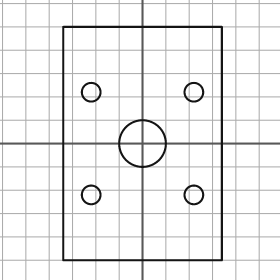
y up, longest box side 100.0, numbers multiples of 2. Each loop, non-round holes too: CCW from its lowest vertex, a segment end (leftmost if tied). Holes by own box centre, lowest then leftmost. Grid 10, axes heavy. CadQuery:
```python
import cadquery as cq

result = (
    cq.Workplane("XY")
    .moveTo(-34.0, -50.0)
    .lineTo(34.0, -50.0)
    .lineTo(34.0, 50.0)
    .lineTo(-34.0, 50.0)
    .close()
    .moveTo(-22.0, -22.0)
    .circle(4.0)
    .moveTo(22.0, -22.0)
    .circle(4.0)
    .moveTo(0.0, 0.0)
    .circle(10.0)
    .moveTo(-22.0, 22.0)
    .circle(4.0)
    .moveTo(22.0, 22.0)
    .circle(4.0)
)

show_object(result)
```